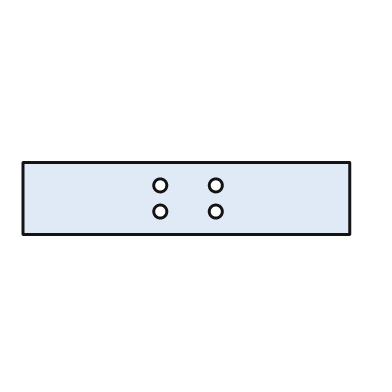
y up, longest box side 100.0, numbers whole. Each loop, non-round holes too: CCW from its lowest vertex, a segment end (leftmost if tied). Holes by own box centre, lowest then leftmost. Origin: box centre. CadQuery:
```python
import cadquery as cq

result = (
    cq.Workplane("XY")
    .moveTo(-50.0, -11.0)
    .lineTo(50.0, -11.0)
    .lineTo(50.0, 11.0)
    .lineTo(-50.0, 11.0)
    .close()
    .moveTo(-8.0, -4.0)
    .circle(2.0)
    .moveTo(9.0, -4.0)
    .circle(2.0)
    .moveTo(-8.0, 4.0)
    .circle(2.0)
    .moveTo(9.0, 4.0)
    .circle(2.0)
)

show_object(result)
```